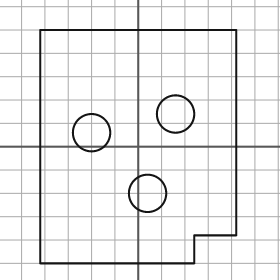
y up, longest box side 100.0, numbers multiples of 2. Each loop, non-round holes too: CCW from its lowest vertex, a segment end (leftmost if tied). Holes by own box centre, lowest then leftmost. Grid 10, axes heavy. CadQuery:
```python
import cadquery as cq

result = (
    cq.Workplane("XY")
    .moveTo(-42.0, -50.0)
    .lineTo(24.0, -50.0)
    .lineTo(24.0, -38.0)
    .lineTo(42.0, -38.0)
    .lineTo(42.0, 50.0)
    .lineTo(-42.0, 50.0)
    .close()
    .moveTo(4.0, -20.0)
    .circle(8.0)
    .moveTo(-20.0, 6.0)
    .circle(8.0)
    .moveTo(16.0, 14.0)
    .circle(8.0)
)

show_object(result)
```